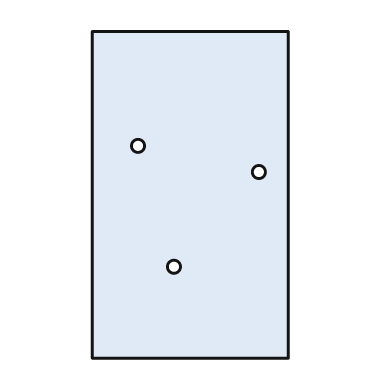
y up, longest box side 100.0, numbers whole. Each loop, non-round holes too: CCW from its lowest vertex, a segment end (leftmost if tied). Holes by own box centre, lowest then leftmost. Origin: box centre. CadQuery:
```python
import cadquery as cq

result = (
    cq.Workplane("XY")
    .moveTo(-30.0, -50.0)
    .lineTo(30.0, -50.0)
    .lineTo(30.0, 50.0)
    .lineTo(-30.0, 50.0)
    .close()
    .moveTo(-5.0, -22.0)
    .circle(2.0)
    .moveTo(21.0, 7.0)
    .circle(2.0)
    .moveTo(-16.0, 15.0)
    .circle(2.0)
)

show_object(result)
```